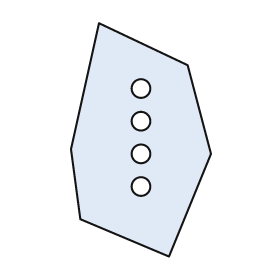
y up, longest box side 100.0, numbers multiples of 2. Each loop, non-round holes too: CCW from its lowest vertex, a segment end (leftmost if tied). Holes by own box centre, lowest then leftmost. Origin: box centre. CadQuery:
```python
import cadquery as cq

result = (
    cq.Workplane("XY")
    .moveTo(12.0, -50.0)
    .lineTo(30.0, -6.0)
    .lineTo(20.0, 32.0)
    .lineTo(-18.0, 50.0)
    .lineTo(-30.0, -4.0)
    .lineTo(-26.0, -34.0)
    .close()
    .moveTo(0.0, -20.0)
    .circle(4.0)
    .moveTo(0.0, -6.0)
    .circle(4.0)
    .moveTo(0.0, 8.0)
    .circle(4.0)
    .moveTo(0.0, 22.0)
    .circle(4.0)
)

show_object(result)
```